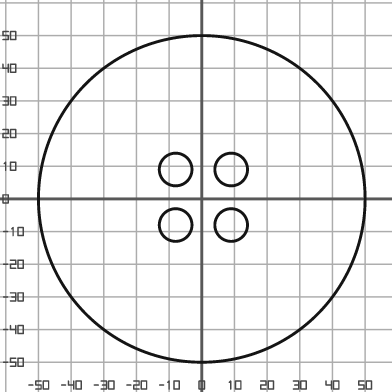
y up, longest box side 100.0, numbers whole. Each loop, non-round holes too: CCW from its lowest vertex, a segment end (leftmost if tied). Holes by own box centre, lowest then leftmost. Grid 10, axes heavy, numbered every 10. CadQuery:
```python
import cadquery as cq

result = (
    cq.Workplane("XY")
    .moveTo(0.0, 0.0)
    .circle(50.0)
    .moveTo(-8.0, -8.0)
    .circle(5.0)
    .moveTo(9.0, -8.0)
    .circle(5.0)
    .moveTo(-8.0, 9.0)
    .circle(5.0)
    .moveTo(9.0, 9.0)
    .circle(5.0)
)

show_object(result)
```